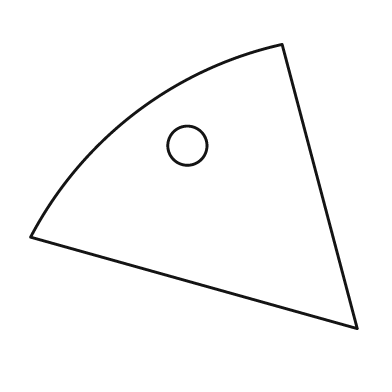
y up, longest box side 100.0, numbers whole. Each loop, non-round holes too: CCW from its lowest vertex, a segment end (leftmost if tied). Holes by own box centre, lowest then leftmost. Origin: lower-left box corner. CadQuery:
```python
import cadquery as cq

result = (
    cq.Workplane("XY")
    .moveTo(100.0, 0.0)
    .lineTo(77.0, 87.0)
    .threePointArc((32.0, 66.0), (0.0, 28.0))
    .close()
    .moveTo(48.0, 56.0)
    .circle(6.0)
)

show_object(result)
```